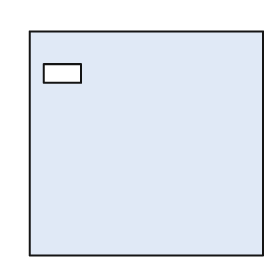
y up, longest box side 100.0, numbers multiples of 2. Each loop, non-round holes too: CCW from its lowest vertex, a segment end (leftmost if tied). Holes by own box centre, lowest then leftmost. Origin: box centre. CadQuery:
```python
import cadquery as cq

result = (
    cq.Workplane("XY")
    .moveTo(-50.0, -48.0)
    .lineTo(50.0, -48.0)
    .lineTo(50.0, 48.0)
    .lineTo(-50.0, 48.0)
    .close()
    .moveTo(-44.0, 26.0)
    .lineTo(-28.0, 26.0)
    .lineTo(-28.0, 34.0)
    .lineTo(-44.0, 34.0)
    .close()
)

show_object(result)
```